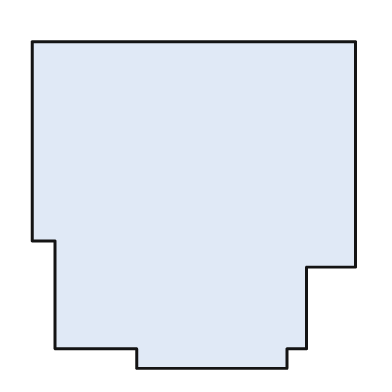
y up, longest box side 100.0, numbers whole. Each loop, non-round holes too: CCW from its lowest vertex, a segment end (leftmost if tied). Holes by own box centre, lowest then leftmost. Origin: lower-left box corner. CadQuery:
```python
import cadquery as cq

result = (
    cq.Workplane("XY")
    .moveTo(32.0, 0.0)
    .lineTo(78.0, 0.0)
    .lineTo(78.0, 6.0)
    .lineTo(84.0, 6.0)
    .lineTo(84.0, 31.0)
    .lineTo(99.0, 31.0)
    .lineTo(99.0, 100.0)
    .lineTo(0.0, 100.0)
    .lineTo(0.0, 39.0)
    .lineTo(7.0, 39.0)
    .lineTo(7.0, 6.0)
    .lineTo(32.0, 6.0)
    .close()
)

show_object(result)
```